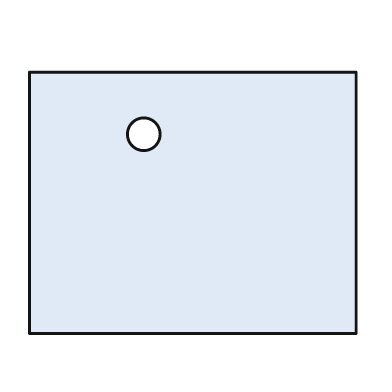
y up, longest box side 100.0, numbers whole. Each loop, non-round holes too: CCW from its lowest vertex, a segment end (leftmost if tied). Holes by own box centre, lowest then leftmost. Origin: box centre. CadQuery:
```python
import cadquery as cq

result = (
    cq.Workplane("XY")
    .moveTo(-50.0, -40.0)
    .lineTo(50.0, -40.0)
    .lineTo(50.0, 40.0)
    .lineTo(-50.0, 40.0)
    .close()
    .moveTo(-15.0, 21.0)
    .circle(5.0)
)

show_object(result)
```